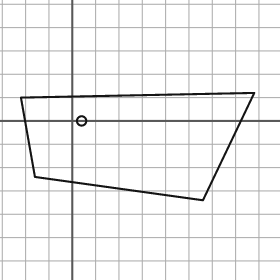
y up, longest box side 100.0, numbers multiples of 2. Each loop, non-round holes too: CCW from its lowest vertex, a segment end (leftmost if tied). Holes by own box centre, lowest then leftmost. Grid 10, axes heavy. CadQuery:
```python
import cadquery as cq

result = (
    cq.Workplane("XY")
    .moveTo(56.0, -34.0)
    .lineTo(78.0, 12.0)
    .lineTo(-22.0, 10.0)
    .lineTo(-16.0, -24.0)
    .close()
    .moveTo(4.0, 0.0)
    .circle(2.0)
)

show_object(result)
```